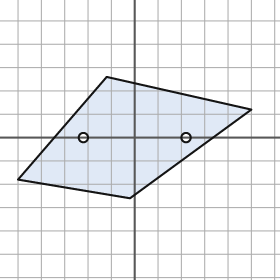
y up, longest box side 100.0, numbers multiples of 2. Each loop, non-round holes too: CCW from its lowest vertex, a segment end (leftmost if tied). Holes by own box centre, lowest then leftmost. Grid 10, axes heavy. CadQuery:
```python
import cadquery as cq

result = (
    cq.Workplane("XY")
    .moveTo(-2.0, -26.0)
    .lineTo(50.0, 12.0)
    .lineTo(-12.0, 26.0)
    .lineTo(-50.0, -18.0)
    .close()
    .moveTo(-22.0, 0.0)
    .circle(2.0)
    .moveTo(22.0, 0.0)
    .circle(2.0)
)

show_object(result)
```